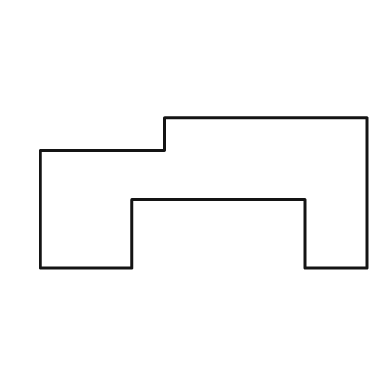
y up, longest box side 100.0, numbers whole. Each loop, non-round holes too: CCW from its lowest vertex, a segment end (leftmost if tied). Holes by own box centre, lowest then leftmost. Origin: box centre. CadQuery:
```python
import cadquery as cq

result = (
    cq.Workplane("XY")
    .moveTo(-50.0, -23.0)
    .lineTo(-22.0, -23.0)
    .lineTo(-22.0, -2.0)
    .lineTo(31.0, -2.0)
    .lineTo(31.0, -23.0)
    .lineTo(50.0, -23.0)
    .lineTo(50.0, 23.0)
    .lineTo(-12.0, 23.0)
    .lineTo(-12.0, 13.0)
    .lineTo(-50.0, 13.0)
    .close()
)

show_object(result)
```